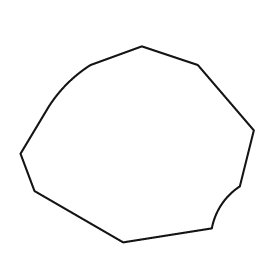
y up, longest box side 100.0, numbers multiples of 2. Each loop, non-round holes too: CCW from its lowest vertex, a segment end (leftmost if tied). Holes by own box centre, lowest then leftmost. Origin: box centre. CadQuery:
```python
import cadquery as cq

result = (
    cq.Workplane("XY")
    .moveTo(-6.0, -42.0)
    .lineTo(32.0, -36.0)
    .threePointArc((36.0, -26.0), (44.0, -18.0))
    .lineTo(50.0, 6.0)
    .lineTo(26.0, 34.0)
    .lineTo(2.0, 42.0)
    .lineTo(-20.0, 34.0)
    .threePointArc((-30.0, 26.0), (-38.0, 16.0))
    .lineTo(-50.0, -4.0)
    .lineTo(-44.0, -20.0)
    .close()
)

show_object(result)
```